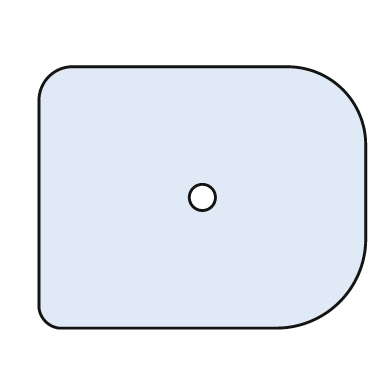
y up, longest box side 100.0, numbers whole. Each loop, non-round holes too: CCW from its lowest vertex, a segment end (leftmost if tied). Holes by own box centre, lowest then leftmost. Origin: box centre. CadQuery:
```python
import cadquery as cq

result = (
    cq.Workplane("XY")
    .moveTo(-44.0, -40.0)
    .lineTo(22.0, -40.0)
    .threePointArc((42.0, -32.0), (50.0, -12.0))
    .lineTo(50.0, 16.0)
    .threePointArc((43.0, 33.0), (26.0, 40.0))
    .lineTo(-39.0, 40.0)
    .threePointArc((-47.0, 37.0), (-50.0, 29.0))
    .lineTo(-50.0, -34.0)
    .threePointArc((-48.0, -38.0), (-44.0, -40.0))
    .close()
    .moveTo(0.0, 0.0)
    .circle(4.0)
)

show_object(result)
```